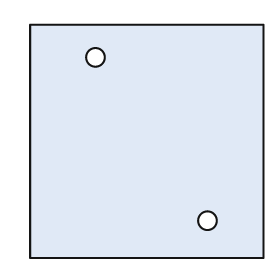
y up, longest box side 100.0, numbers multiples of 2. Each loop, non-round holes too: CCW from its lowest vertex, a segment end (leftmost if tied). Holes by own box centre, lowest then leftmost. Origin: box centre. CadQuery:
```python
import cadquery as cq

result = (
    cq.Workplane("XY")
    .moveTo(-50.0, -50.0)
    .lineTo(50.0, -50.0)
    .lineTo(50.0, 50.0)
    .lineTo(-50.0, 50.0)
    .close()
    .moveTo(26.0, -34.0)
    .circle(4.0)
    .moveTo(-22.0, 36.0)
    .circle(4.0)
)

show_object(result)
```